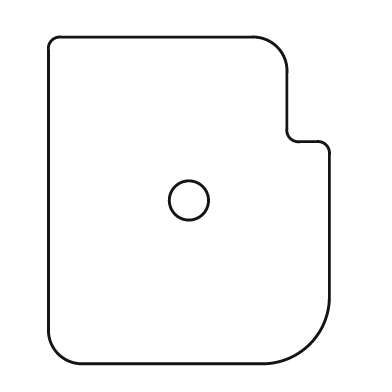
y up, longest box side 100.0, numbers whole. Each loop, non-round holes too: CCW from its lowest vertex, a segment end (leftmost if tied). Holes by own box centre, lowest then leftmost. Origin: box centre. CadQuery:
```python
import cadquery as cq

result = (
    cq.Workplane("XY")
    .moveTo(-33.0, -50.0)
    .lineTo(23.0, -50.0)
    .threePointArc((37.0, -44.0), (43.0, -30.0))
    .lineTo(43.0, 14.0)
    .threePointArc((42.0, 17.0), (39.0, 18.0))
    .lineTo(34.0, 18.0)
    .threePointArc((31.0, 19.0), (30.0, 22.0))
    .lineTo(30.0, 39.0)
    .threePointArc((27.0, 47.0), (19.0, 50.0))
    .lineTo(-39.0, 50.0)
    .threePointArc((-42.0, 49.0), (-43.0, 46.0))
    .lineTo(-43.0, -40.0)
    .threePointArc((-40.0, -47.0), (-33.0, -50.0))
    .close()
    .moveTo(0.0, 0.0)
    .circle(6.0)
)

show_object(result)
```